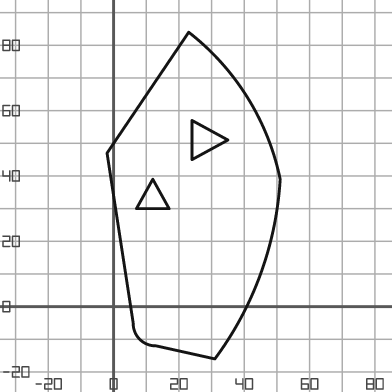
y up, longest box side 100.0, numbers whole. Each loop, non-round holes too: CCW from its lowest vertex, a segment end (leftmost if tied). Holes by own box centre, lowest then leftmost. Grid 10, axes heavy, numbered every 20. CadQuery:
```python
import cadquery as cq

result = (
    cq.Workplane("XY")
    .moveTo(31.0, -16.0)
    .threePointArc((45.0, 10.0), (51.0, 39.0))
    .threePointArc((41.0, 64.0), (23.0, 84.0))
    .lineTo(-2.0, 47.0)
    .lineTo(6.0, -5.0)
    .threePointArc((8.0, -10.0), (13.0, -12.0))
    .close()
    .moveTo(7.0, 30.0)
    .lineTo(17.0, 30.0)
    .lineTo(12.0, 39.0)
    .close()
    .moveTo(24.0, 45.0)
    .lineTo(35.0, 51.0)
    .lineTo(24.0, 57.0)
    .close()
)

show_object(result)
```